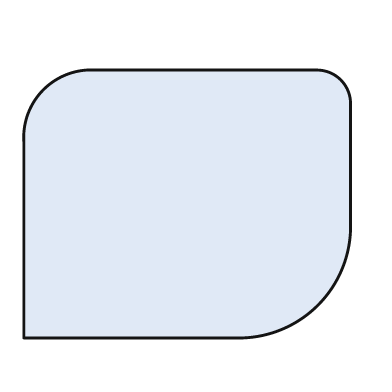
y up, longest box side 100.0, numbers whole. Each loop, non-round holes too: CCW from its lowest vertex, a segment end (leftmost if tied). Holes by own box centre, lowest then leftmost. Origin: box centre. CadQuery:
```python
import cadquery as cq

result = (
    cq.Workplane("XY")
    .moveTo(-50.0, -41.0)
    .lineTo(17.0, -41.0)
    .threePointArc((40.0, -31.0), (50.0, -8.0))
    .lineTo(50.0, 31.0)
    .threePointArc((47.0, 38.0), (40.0, 41.0))
    .lineTo(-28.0, 41.0)
    .threePointArc((-44.0, 35.0), (-50.0, 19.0))
    .close()
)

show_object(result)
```